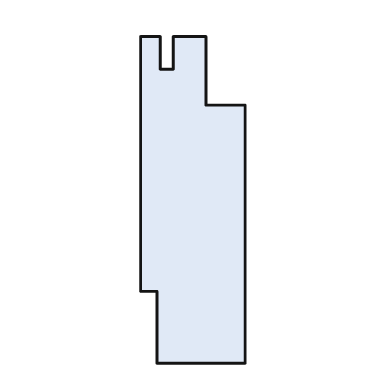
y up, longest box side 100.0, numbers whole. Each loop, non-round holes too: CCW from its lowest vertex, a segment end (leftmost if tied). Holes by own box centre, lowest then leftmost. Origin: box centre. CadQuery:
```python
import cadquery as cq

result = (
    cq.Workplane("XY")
    .moveTo(-11.0, -50.0)
    .lineTo(16.0, -50.0)
    .lineTo(16.0, 29.0)
    .lineTo(4.0, 29.0)
    .lineTo(4.0, 50.0)
    .lineTo(-6.0, 50.0)
    .lineTo(-6.0, 40.0)
    .lineTo(-10.0, 40.0)
    .lineTo(-10.0, 50.0)
    .lineTo(-16.0, 50.0)
    .lineTo(-16.0, -28.0)
    .lineTo(-11.0, -28.0)
    .close()
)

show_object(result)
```